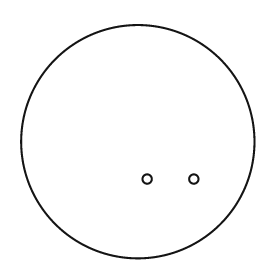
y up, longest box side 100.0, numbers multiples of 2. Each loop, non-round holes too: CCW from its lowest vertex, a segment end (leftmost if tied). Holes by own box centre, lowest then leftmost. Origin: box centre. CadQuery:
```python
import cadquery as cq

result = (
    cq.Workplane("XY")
    .moveTo(0.0, 0.0)
    .circle(50.0)
    .moveTo(4.0, -16.0)
    .circle(2.0)
    .moveTo(24.0, -16.0)
    .circle(2.0)
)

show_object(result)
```